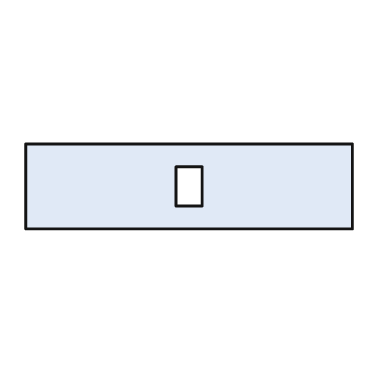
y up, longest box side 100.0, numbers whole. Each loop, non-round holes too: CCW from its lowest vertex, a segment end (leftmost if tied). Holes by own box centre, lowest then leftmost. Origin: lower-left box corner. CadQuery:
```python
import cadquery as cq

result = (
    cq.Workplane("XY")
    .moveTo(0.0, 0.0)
    .lineTo(100.0, 0.0)
    .lineTo(100.0, 26.0)
    .lineTo(0.0, 26.0)
    .close()
    .moveTo(46.0, 7.0)
    .lineTo(54.0, 7.0)
    .lineTo(54.0, 19.0)
    .lineTo(46.0, 19.0)
    .close()
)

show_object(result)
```